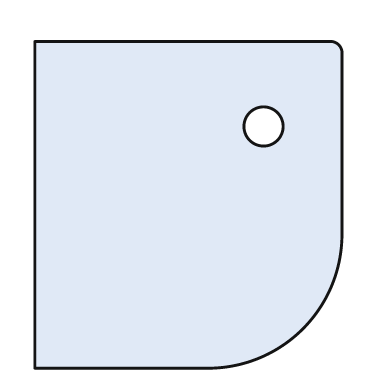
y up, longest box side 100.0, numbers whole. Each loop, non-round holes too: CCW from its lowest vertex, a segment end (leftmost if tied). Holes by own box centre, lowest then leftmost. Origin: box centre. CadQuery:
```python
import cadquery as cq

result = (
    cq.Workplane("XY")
    .moveTo(-47.0, -50.0)
    .lineTo(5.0, -50.0)
    .threePointArc((35.0, -38.0), (47.0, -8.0))
    .lineTo(47.0, 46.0)
    .threePointArc((46.0, 49.0), (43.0, 50.0))
    .lineTo(-47.0, 50.0)
    .close()
    .moveTo(23.0, 24.0)
    .circle(6.0)
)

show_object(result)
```